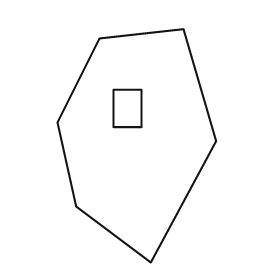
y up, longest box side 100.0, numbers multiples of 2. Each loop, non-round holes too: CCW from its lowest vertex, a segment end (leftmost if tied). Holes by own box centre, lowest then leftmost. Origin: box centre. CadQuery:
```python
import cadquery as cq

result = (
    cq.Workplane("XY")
    .moveTo(6.0, -50.0)
    .lineTo(34.0, 2.0)
    .lineTo(20.0, 50.0)
    .lineTo(-16.0, 46.0)
    .lineTo(-34.0, 10.0)
    .lineTo(-26.0, -26.0)
    .close()
    .moveTo(-10.0, 8.0)
    .lineTo(2.0, 8.0)
    .lineTo(2.0, 24.0)
    .lineTo(-10.0, 24.0)
    .close()
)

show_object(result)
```